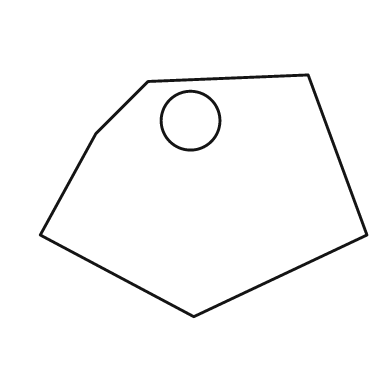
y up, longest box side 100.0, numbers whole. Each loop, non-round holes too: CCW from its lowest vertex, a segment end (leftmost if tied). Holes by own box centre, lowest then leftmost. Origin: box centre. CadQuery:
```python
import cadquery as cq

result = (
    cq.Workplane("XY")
    .moveTo(-3.0, -37.0)
    .lineTo(50.0, -12.0)
    .lineTo(32.0, 37.0)
    .lineTo(-17.0, 35.0)
    .lineTo(-33.0, 19.0)
    .lineTo(-50.0, -12.0)
    .close()
    .moveTo(-4.0, 23.0)
    .circle(9.0)
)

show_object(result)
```